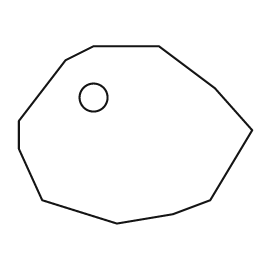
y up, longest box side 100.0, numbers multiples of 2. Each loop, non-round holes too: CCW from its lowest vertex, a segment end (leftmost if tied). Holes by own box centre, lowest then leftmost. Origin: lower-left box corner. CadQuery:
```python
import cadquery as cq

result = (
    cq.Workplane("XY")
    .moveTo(42.0, 0.0)
    .lineTo(66.0, 4.0)
    .lineTo(82.0, 10.0)
    .lineTo(100.0, 40.0)
    .lineTo(84.0, 58.0)
    .lineTo(60.0, 76.0)
    .lineTo(32.0, 76.0)
    .lineTo(20.0, 70.0)
    .lineTo(0.0, 44.0)
    .lineTo(0.0, 32.0)
    .lineTo(10.0, 10.0)
    .close()
    .moveTo(32.0, 54.0)
    .circle(6.0)
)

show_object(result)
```